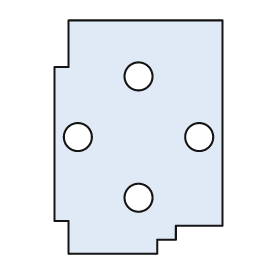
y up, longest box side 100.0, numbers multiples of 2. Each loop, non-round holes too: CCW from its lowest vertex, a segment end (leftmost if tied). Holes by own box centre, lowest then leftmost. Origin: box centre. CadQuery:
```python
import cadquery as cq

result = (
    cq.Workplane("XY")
    .moveTo(-30.0, -50.0)
    .lineTo(8.0, -50.0)
    .lineTo(8.0, -44.0)
    .lineTo(16.0, -44.0)
    .lineTo(16.0, -38.0)
    .lineTo(36.0, -38.0)
    .lineTo(36.0, 50.0)
    .lineTo(-30.0, 50.0)
    .lineTo(-30.0, 30.0)
    .lineTo(-36.0, 30.0)
    .lineTo(-36.0, -36.0)
    .lineTo(-30.0, -36.0)
    .close()
    .moveTo(0.0, -26.0)
    .circle(6.0)
    .moveTo(-26.0, 0.0)
    .circle(6.0)
    .moveTo(26.0, 0.0)
    .circle(6.0)
    .moveTo(0.0, 26.0)
    .circle(6.0)
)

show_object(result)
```